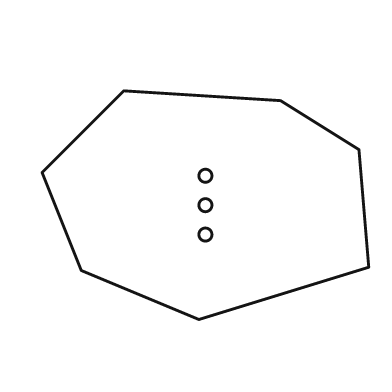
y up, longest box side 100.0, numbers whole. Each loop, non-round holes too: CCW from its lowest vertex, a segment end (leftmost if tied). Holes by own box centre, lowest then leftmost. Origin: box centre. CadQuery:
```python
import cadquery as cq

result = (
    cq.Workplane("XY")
    .moveTo(-2.0, -35.0)
    .lineTo(50.0, -19.0)
    .lineTo(47.0, 17.0)
    .lineTo(23.0, 32.0)
    .lineTo(-25.0, 35.0)
    .lineTo(-50.0, 10.0)
    .lineTo(-38.0, -20.0)
    .close()
    .moveTo(0.0, -9.0)
    .circle(2.0)
    .moveTo(0.0, 0.0)
    .circle(2.0)
    .moveTo(0.0, 9.0)
    .circle(2.0)
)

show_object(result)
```